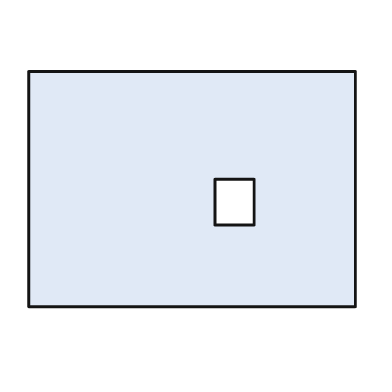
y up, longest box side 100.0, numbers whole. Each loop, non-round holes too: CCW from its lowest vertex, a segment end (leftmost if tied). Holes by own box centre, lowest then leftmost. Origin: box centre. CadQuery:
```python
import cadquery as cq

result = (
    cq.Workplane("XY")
    .moveTo(-50.0, -36.0)
    .lineTo(50.0, -36.0)
    .lineTo(50.0, 36.0)
    .lineTo(-50.0, 36.0)
    .close()
    .moveTo(7.0, -11.0)
    .lineTo(19.0, -11.0)
    .lineTo(19.0, 3.0)
    .lineTo(7.0, 3.0)
    .close()
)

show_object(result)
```